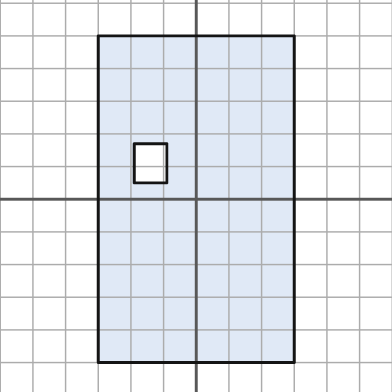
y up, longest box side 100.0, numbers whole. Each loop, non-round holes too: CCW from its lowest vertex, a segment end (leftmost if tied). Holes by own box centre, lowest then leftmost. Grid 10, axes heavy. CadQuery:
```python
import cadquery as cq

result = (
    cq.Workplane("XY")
    .moveTo(-30.0, -50.0)
    .lineTo(30.0, -50.0)
    .lineTo(30.0, 50.0)
    .lineTo(-30.0, 50.0)
    .close()
    .moveTo(-19.0, 5.0)
    .lineTo(-9.0, 5.0)
    .lineTo(-9.0, 17.0)
    .lineTo(-19.0, 17.0)
    .close()
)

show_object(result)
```